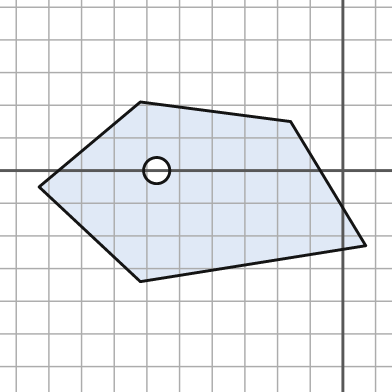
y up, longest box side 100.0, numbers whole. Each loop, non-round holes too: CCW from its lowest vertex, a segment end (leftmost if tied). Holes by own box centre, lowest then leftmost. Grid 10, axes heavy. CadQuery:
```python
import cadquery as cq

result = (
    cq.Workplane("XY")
    .moveTo(-62.0, -34.0)
    .lineTo(7.0, -23.0)
    .lineTo(-16.0, 15.0)
    .lineTo(-62.0, 21.0)
    .lineTo(-93.0, -5.0)
    .close()
    .moveTo(-57.0, 0.0)
    .circle(4.0)
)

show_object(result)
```